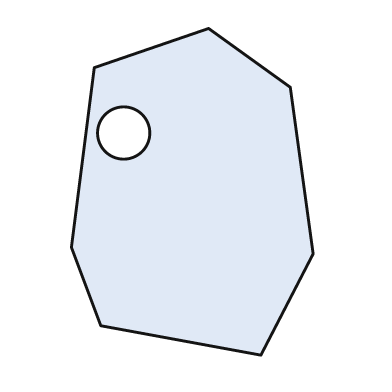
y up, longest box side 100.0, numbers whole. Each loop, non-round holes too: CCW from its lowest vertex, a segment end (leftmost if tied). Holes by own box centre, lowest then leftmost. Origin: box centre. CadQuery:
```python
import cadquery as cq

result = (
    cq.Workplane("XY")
    .moveTo(21.0, -50.0)
    .lineTo(37.0, -19.0)
    .lineTo(30.0, 32.0)
    .lineTo(5.0, 50.0)
    .lineTo(-30.0, 38.0)
    .lineTo(-37.0, -17.0)
    .lineTo(-28.0, -41.0)
    .close()
    .moveTo(-21.0, 18.0)
    .circle(8.0)
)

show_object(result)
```